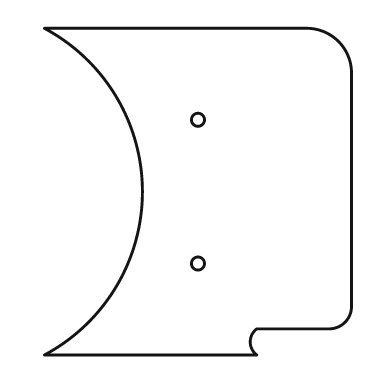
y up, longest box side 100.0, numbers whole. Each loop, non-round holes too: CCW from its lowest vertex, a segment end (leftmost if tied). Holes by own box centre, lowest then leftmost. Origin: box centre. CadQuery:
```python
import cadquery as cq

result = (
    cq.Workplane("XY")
    .moveTo(-47.0, -50.0)
    .lineTo(18.0, -50.0)
    .threePointArc((16.0, -46.0), (18.0, -42.0))
    .lineTo(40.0, -42.0)
    .threePointArc((45.0, -40.0), (47.0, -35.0))
    .lineTo(47.0, 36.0)
    .threePointArc((43.0, 46.0), (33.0, 50.0))
    .lineTo(-47.0, 50.0)
    .threePointArc((-17.0, 0.0), (-47.0, -50.0))
    .close()
    .moveTo(0.0, -22.0)
    .circle(2.0)
    .moveTo(0.0, 22.0)
    .circle(2.0)
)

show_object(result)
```